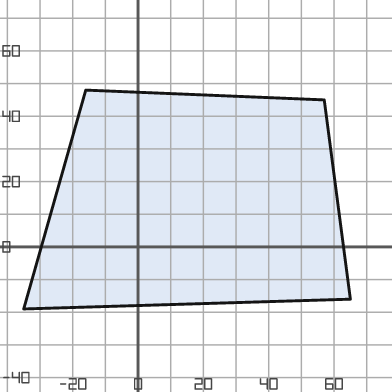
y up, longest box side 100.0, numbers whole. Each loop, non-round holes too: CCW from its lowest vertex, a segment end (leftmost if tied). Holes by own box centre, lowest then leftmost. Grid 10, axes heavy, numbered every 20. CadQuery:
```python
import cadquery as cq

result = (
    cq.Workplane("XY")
    .moveTo(-35.0, -19.0)
    .lineTo(65.0, -16.0)
    .lineTo(57.0, 45.0)
    .lineTo(-16.0, 48.0)
    .close()
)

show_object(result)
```